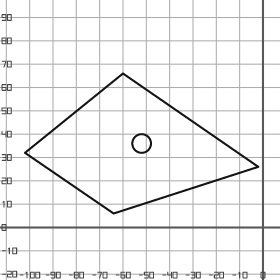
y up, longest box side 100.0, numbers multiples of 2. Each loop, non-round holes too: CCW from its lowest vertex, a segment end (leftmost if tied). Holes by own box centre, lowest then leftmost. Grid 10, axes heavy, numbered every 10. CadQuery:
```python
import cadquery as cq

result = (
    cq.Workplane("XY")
    .moveTo(-64.0, 6.0)
    .lineTo(-2.0, 26.0)
    .lineTo(-60.0, 66.0)
    .lineTo(-102.0, 32.0)
    .close()
    .moveTo(-52.0, 36.0)
    .circle(4.0)
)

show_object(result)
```